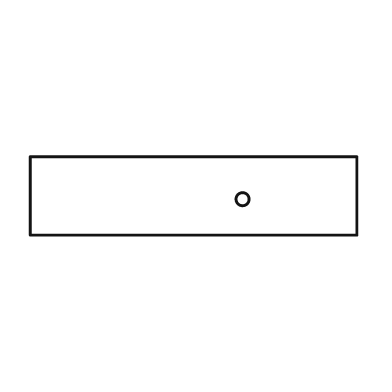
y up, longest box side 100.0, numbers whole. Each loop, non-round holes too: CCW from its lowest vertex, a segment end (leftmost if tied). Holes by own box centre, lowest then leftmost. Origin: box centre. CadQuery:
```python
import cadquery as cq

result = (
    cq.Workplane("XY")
    .moveTo(-50.0, -12.0)
    .lineTo(50.0, -12.0)
    .lineTo(50.0, 12.0)
    .lineTo(-50.0, 12.0)
    .close()
    .moveTo(15.0, -1.0)
    .circle(2.0)
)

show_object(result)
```